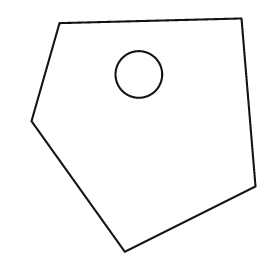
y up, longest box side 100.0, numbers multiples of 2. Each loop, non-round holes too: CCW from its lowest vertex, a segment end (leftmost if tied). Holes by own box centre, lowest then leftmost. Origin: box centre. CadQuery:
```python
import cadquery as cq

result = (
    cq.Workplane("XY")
    .moveTo(-8.0, -50.0)
    .lineTo(48.0, -22.0)
    .lineTo(42.0, 50.0)
    .lineTo(-36.0, 48.0)
    .lineTo(-48.0, 6.0)
    .close()
    .moveTo(-2.0, 26.0)
    .circle(10.0)
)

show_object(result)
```